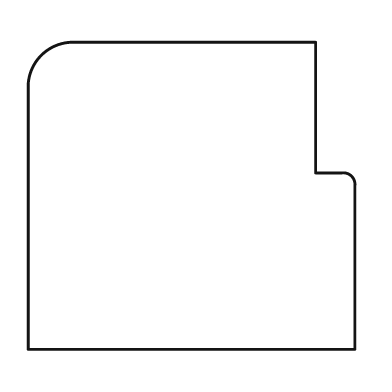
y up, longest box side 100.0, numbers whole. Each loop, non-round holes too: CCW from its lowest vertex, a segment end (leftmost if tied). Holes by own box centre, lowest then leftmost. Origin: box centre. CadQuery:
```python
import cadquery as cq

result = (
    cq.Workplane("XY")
    .moveTo(-50.0, -47.0)
    .lineTo(50.0, -47.0)
    .lineTo(50.0, 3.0)
    .threePointArc((49.0, 6.0), (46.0, 7.0))
    .lineTo(38.0, 7.0)
    .lineTo(38.0, 47.0)
    .lineTo(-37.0, 47.0)
    .threePointArc((-46.0, 43.0), (-50.0, 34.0))
    .close()
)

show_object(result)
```